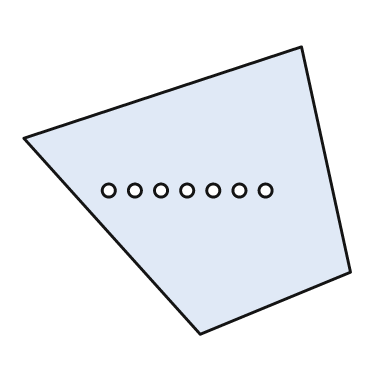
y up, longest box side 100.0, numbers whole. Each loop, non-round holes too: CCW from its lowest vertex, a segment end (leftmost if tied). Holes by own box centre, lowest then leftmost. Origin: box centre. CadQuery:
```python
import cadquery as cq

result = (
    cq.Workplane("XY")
    .moveTo(4.0, -44.0)
    .lineTo(50.0, -25.0)
    .lineTo(35.0, 44.0)
    .lineTo(-50.0, 16.0)
    .close()
    .moveTo(-24.0, 0.0)
    .circle(2.0)
    .moveTo(-16.0, 0.0)
    .circle(2.0)
    .moveTo(-8.0, 0.0)
    .circle(2.0)
    .moveTo(0.0, 0.0)
    .circle(2.0)
    .moveTo(8.0, 0.0)
    .circle(2.0)
    .moveTo(16.0, 0.0)
    .circle(2.0)
    .moveTo(24.0, 0.0)
    .circle(2.0)
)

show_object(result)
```